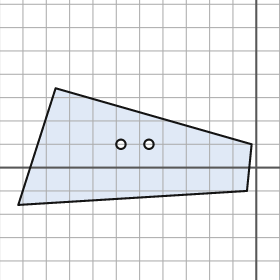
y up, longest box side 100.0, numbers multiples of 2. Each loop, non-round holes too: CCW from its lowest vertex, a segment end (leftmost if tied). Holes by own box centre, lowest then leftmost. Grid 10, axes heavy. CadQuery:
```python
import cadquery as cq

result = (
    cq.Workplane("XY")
    .moveTo(-102.0, -16.0)
    .lineTo(-4.0, -10.0)
    .lineTo(-2.0, 10.0)
    .lineTo(-86.0, 34.0)
    .close()
    .moveTo(-58.0, 10.0)
    .circle(2.0)
    .moveTo(-46.0, 10.0)
    .circle(2.0)
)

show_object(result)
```